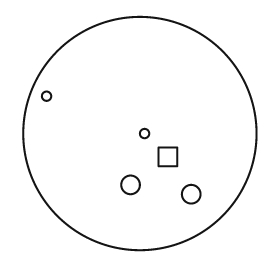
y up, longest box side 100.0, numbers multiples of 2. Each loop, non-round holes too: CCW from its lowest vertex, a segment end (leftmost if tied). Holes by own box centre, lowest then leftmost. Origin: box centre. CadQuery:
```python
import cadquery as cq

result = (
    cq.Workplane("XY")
    .moveTo(0.0, 0.0)
    .circle(50.0)
    .moveTo(22.0, -26.0)
    .circle(4.0)
    .moveTo(-4.0, -22.0)
    .circle(4.0)
    .moveTo(8.0, -14.0)
    .lineTo(16.0, -14.0)
    .lineTo(16.0, -6.0)
    .lineTo(8.0, -6.0)
    .close()
    .moveTo(2.0, 0.0)
    .circle(2.0)
    .moveTo(-40.0, 16.0)
    .circle(2.0)
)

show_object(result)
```